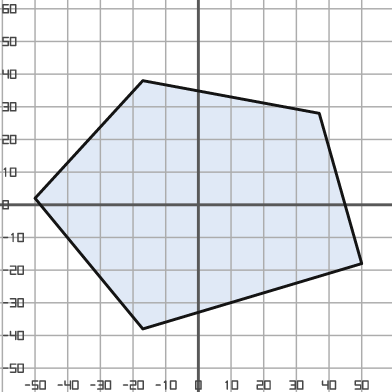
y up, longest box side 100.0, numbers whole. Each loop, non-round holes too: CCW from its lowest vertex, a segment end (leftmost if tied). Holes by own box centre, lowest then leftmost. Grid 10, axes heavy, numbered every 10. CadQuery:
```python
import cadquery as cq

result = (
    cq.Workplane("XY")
    .moveTo(-17.0, -38.0)
    .lineTo(50.0, -18.0)
    .lineTo(37.0, 28.0)
    .lineTo(-17.0, 38.0)
    .lineTo(-50.0, 2.0)
    .close()
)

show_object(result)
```